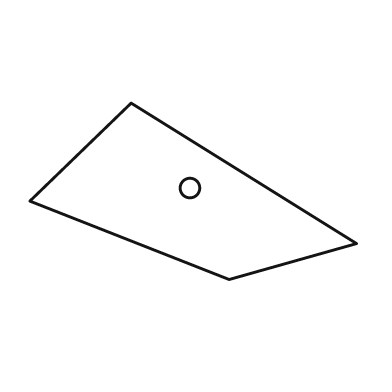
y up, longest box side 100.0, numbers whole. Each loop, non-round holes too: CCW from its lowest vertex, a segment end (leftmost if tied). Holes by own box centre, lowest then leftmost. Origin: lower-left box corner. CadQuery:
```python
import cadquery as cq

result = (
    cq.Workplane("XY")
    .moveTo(61.0, 0.0)
    .lineTo(100.0, 11.0)
    .lineTo(31.0, 54.0)
    .lineTo(0.0, 24.0)
    .close()
    .moveTo(49.0, 28.0)
    .circle(3.0)
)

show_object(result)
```